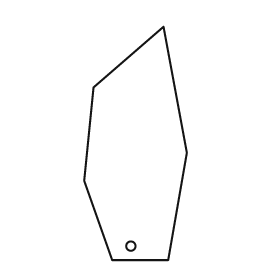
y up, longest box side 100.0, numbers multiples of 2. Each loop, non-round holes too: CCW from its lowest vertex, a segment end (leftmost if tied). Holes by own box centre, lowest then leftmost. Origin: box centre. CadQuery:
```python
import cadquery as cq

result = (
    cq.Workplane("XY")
    .moveTo(-10.0, -50.0)
    .lineTo(14.0, -50.0)
    .lineTo(22.0, -4.0)
    .lineTo(12.0, 50.0)
    .lineTo(-18.0, 24.0)
    .lineTo(-22.0, -16.0)
    .close()
    .moveTo(-2.0, -44.0)
    .circle(2.0)
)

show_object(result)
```